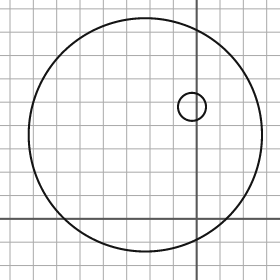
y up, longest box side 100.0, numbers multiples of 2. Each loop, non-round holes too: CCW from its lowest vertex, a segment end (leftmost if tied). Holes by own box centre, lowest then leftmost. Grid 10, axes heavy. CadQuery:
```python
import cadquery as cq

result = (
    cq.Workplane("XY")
    .moveTo(-22.0, 36.0)
    .circle(50.0)
    .moveTo(-2.0, 48.0)
    .circle(6.0)
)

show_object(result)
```